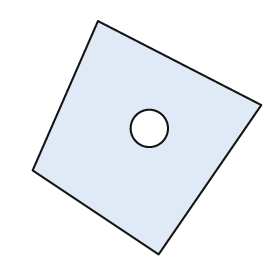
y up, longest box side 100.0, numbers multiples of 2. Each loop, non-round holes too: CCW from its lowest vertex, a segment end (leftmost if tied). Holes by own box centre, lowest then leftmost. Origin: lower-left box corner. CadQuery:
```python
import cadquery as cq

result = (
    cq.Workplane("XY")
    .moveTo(54.0, 0.0)
    .lineTo(98.0, 64.0)
    .lineTo(28.0, 100.0)
    .lineTo(0.0, 36.0)
    .close()
    .moveTo(50.0, 54.0)
    .circle(8.0)
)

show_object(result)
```